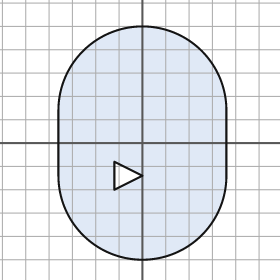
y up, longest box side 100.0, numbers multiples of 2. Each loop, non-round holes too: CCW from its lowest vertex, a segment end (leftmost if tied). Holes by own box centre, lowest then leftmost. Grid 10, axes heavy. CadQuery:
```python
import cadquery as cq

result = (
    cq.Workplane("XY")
    .moveTo(-36.0, -14.0)
    .threePointArc((0.0, -50.0), (36.0, -14.0))
    .lineTo(36.0, 14.0)
    .threePointArc((0.0, 50.0), (-36.0, 14.0))
    .close()
    .moveTo(-12.0, -20.0)
    .lineTo(0.0, -14.0)
    .lineTo(-12.0, -8.0)
    .close()
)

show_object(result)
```